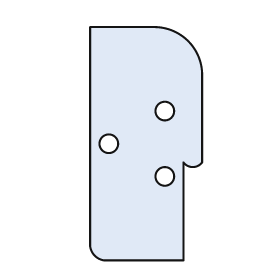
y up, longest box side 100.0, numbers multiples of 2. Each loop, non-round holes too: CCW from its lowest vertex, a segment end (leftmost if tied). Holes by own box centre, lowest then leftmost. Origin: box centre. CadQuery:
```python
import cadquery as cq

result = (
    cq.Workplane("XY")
    .moveTo(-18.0, -50.0)
    .lineTo(16.0, -50.0)
    .lineTo(16.0, -8.0)
    .threePointArc((20.0, -10.0), (24.0, -8.0))
    .lineTo(24.0, 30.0)
    .threePointArc((18.0, 44.0), (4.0, 50.0))
    .lineTo(-24.0, 50.0)
    .lineTo(-24.0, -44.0)
    .threePointArc((-22.0, -48.0), (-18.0, -50.0))
    .close()
    .moveTo(8.0, -14.0)
    .circle(4.0)
    .moveTo(-16.0, 0.0)
    .circle(4.0)
    .moveTo(8.0, 14.0)
    .circle(4.0)
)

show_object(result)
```